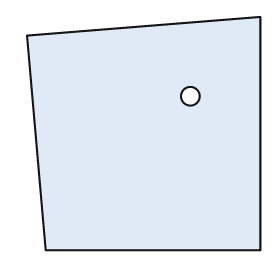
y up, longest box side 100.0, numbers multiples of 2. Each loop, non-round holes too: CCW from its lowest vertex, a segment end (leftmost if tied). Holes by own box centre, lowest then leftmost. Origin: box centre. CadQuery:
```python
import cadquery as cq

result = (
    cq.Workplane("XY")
    .moveTo(-42.0, -50.0)
    .lineTo(50.0, -50.0)
    .lineTo(50.0, 50.0)
    .lineTo(-50.0, 42.0)
    .close()
    .moveTo(20.0, 16.0)
    .circle(4.0)
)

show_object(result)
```